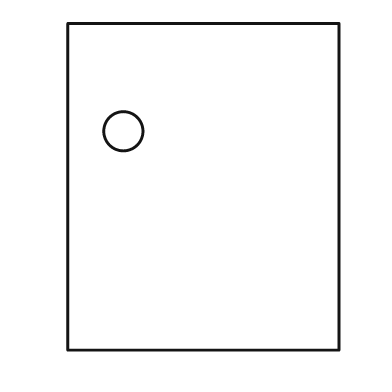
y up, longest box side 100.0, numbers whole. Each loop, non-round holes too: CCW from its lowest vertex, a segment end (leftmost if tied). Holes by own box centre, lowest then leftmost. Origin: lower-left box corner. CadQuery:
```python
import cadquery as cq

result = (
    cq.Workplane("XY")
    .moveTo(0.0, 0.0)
    .lineTo(83.0, 0.0)
    .lineTo(83.0, 100.0)
    .lineTo(0.0, 100.0)
    .close()
    .moveTo(17.0, 67.0)
    .circle(6.0)
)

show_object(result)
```